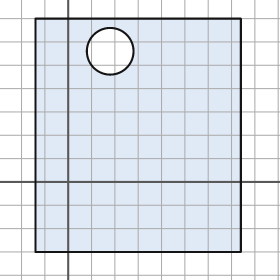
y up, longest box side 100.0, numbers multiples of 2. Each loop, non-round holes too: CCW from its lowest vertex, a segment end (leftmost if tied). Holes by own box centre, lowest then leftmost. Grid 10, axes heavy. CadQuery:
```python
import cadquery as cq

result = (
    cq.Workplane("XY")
    .moveTo(-14.0, -30.0)
    .lineTo(74.0, -30.0)
    .lineTo(74.0, 70.0)
    .lineTo(-14.0, 70.0)
    .close()
    .moveTo(18.0, 56.0)
    .circle(10.0)
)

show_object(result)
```